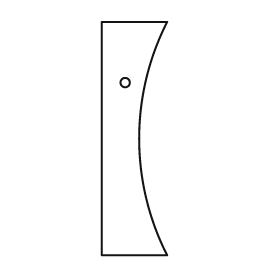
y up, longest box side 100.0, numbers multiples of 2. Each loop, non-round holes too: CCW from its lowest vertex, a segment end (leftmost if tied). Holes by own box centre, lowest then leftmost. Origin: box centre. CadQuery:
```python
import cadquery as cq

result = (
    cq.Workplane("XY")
    .moveTo(-14.0, -50.0)
    .lineTo(14.0, -50.0)
    .threePointArc((2.0, 0.0), (14.0, 50.0))
    .lineTo(-14.0, 50.0)
    .close()
    .moveTo(-4.0, 24.0)
    .circle(2.0)
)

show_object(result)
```